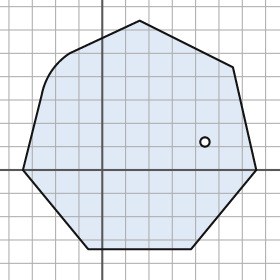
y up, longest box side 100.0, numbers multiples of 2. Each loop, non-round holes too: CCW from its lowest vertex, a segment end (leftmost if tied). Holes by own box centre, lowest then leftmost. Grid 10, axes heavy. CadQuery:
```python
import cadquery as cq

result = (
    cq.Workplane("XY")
    .moveTo(-6.0, -34.0)
    .lineTo(38.0, -34.0)
    .lineTo(66.0, 0.0)
    .lineTo(56.0, 44.0)
    .lineTo(16.0, 64.0)
    .lineTo(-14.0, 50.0)
    .threePointArc((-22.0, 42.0), (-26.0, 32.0))
    .lineTo(-34.0, 0.0)
    .close()
    .moveTo(44.0, 12.0)
    .circle(2.0)
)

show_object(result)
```